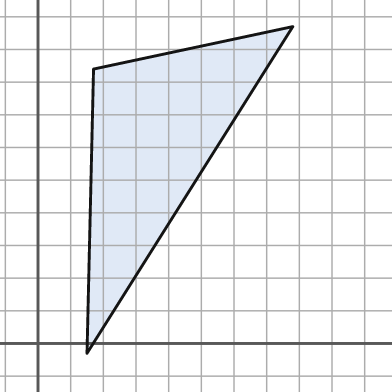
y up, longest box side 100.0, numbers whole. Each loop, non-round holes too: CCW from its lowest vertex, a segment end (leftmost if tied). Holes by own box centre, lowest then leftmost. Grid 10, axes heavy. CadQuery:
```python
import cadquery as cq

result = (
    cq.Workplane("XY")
    .moveTo(15.0, -3.0)
    .lineTo(78.0, 97.0)
    .lineTo(17.0, 84.0)
    .close()
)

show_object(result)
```